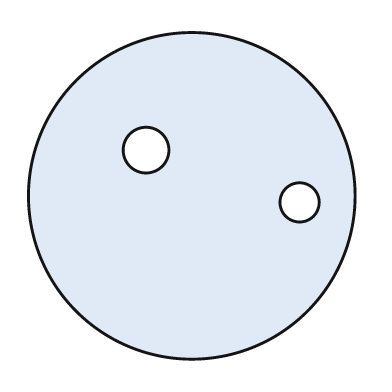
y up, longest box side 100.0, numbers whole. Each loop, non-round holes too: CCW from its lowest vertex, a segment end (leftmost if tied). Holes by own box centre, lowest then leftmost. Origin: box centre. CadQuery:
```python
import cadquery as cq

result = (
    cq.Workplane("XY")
    .moveTo(0.0, 0.0)
    .circle(50.0)
    .moveTo(33.0, -2.0)
    .circle(6.0)
    .moveTo(-14.0, 14.0)
    .circle(7.0)
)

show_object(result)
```